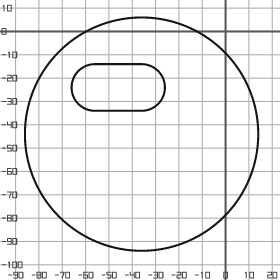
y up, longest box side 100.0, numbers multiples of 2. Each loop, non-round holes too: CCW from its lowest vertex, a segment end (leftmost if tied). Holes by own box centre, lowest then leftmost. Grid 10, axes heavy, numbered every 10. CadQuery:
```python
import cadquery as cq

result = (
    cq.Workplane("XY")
    .moveTo(-36.0, -44.0)
    .circle(50.0)
    .moveTo(-56.0, -34.0)
    .lineTo(-36.0, -34.0)
    .threePointArc((-26.0, -24.0), (-36.0, -14.0))
    .lineTo(-56.0, -14.0)
    .threePointArc((-66.0, -24.0), (-56.0, -34.0))
    .close()
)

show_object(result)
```